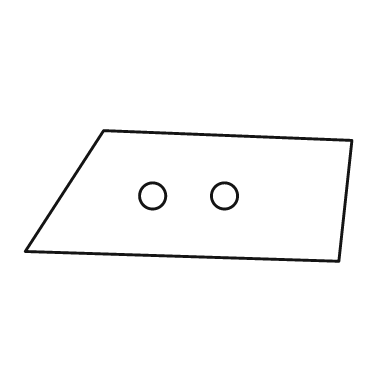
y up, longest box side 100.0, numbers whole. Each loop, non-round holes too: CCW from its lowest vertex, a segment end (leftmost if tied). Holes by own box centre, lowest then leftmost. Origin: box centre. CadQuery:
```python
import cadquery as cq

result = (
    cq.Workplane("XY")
    .moveTo(46.0, -20.0)
    .lineTo(50.0, 17.0)
    .lineTo(-26.0, 20.0)
    .lineTo(-50.0, -17.0)
    .close()
    .moveTo(-11.0, 0.0)
    .circle(4.0)
    .moveTo(11.0, 0.0)
    .circle(4.0)
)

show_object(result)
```